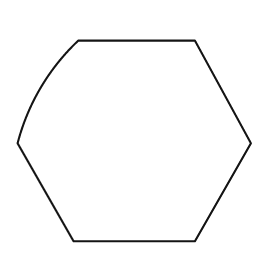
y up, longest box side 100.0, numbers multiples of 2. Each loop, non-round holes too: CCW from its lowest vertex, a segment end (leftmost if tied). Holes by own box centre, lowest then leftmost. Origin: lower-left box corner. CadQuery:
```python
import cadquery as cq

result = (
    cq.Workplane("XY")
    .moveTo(24.0, 0.0)
    .lineTo(76.0, 0.0)
    .lineTo(100.0, 42.0)
    .lineTo(76.0, 86.0)
    .lineTo(26.0, 86.0)
    .threePointArc((10.0, 66.0), (0.0, 42.0))
    .close()
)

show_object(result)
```